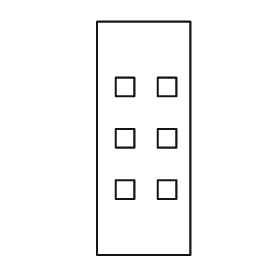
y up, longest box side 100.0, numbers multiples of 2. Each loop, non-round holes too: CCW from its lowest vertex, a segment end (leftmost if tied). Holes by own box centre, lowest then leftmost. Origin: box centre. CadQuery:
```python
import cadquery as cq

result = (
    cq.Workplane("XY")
    .moveTo(-20.0, -50.0)
    .lineTo(20.0, -50.0)
    .lineTo(20.0, 50.0)
    .lineTo(-20.0, 50.0)
    .close()
    .moveTo(-12.0, -26.0)
    .lineTo(-4.0, -26.0)
    .lineTo(-4.0, -18.0)
    .lineTo(-12.0, -18.0)
    .close()
    .moveTo(6.0, -26.0)
    .lineTo(14.0, -26.0)
    .lineTo(14.0, -18.0)
    .lineTo(6.0, -18.0)
    .close()
    .moveTo(-12.0, -4.0)
    .lineTo(-4.0, -4.0)
    .lineTo(-4.0, 4.0)
    .lineTo(-12.0, 4.0)
    .close()
    .moveTo(6.0, -4.0)
    .lineTo(14.0, -4.0)
    .lineTo(14.0, 4.0)
    .lineTo(6.0, 4.0)
    .close()
    .moveTo(-12.0, 18.0)
    .lineTo(-4.0, 18.0)
    .lineTo(-4.0, 26.0)
    .lineTo(-12.0, 26.0)
    .close()
    .moveTo(6.0, 18.0)
    .lineTo(14.0, 18.0)
    .lineTo(14.0, 26.0)
    .lineTo(6.0, 26.0)
    .close()
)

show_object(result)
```